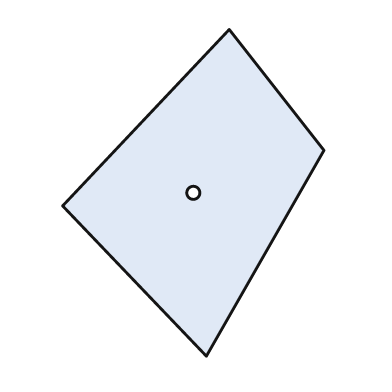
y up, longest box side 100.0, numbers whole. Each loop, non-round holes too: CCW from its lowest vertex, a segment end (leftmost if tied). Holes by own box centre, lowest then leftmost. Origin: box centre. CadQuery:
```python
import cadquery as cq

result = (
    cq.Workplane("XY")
    .moveTo(4.0, -50.0)
    .lineTo(40.0, 13.0)
    .lineTo(11.0, 50.0)
    .lineTo(-40.0, -4.0)
    .close()
    .moveTo(0.0, 0.0)
    .circle(2.0)
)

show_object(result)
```